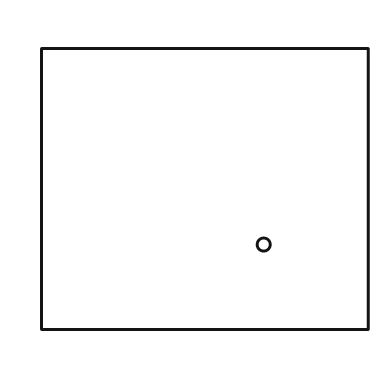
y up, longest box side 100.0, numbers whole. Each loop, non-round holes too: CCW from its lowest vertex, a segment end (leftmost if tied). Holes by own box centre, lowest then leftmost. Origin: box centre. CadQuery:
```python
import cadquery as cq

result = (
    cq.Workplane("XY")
    .moveTo(-50.0, -43.0)
    .lineTo(50.0, -43.0)
    .lineTo(50.0, 43.0)
    .lineTo(-50.0, 43.0)
    .close()
    .moveTo(18.0, -17.0)
    .circle(2.0)
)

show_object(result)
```